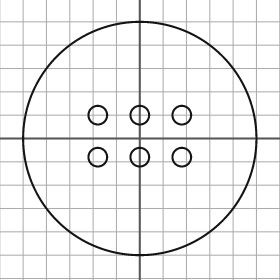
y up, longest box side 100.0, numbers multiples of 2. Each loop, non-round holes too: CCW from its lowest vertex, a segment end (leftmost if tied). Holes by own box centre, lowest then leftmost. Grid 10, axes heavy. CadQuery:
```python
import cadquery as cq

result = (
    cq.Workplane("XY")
    .moveTo(0.0, 0.0)
    .circle(50.0)
    .moveTo(-18.0, -8.0)
    .circle(4.0)
    .moveTo(0.0, -8.0)
    .circle(4.0)
    .moveTo(18.0, -8.0)
    .circle(4.0)
    .moveTo(-18.0, 10.0)
    .circle(4.0)
    .moveTo(0.0, 10.0)
    .circle(4.0)
    .moveTo(18.0, 10.0)
    .circle(4.0)
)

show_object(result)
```